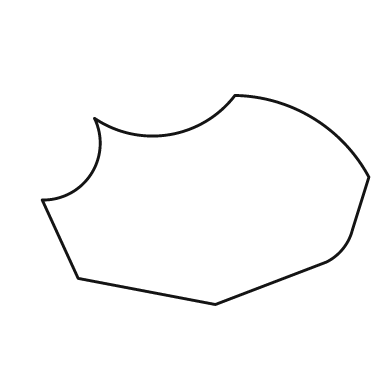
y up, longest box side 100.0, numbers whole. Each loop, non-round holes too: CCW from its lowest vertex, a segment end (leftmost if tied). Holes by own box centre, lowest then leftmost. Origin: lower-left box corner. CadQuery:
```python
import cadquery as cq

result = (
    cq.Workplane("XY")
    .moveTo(53.0, 0.0)
    .lineTo(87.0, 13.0)
    .threePointArc((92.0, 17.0), (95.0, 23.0))
    .lineTo(100.0, 39.0)
    .threePointArc((83.0, 57.0), (59.0, 64.0))
    .threePointArc((39.0, 52.0), (16.0, 57.0))
    .threePointArc((15.0, 40.0), (0.0, 32.0))
    .lineTo(11.0, 8.0)
    .close()
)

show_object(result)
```